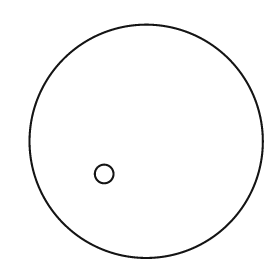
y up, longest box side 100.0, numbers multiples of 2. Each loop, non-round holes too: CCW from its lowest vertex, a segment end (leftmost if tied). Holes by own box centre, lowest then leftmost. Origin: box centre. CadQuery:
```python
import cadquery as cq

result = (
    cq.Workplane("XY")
    .moveTo(0.0, 0.0)
    .circle(50.0)
    .moveTo(-18.0, -14.0)
    .circle(4.0)
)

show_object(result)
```